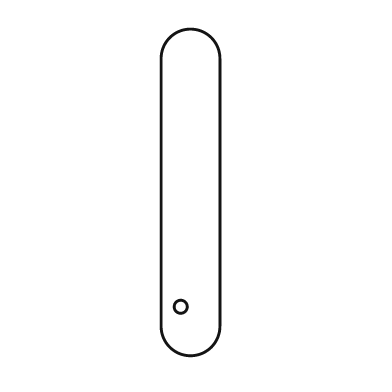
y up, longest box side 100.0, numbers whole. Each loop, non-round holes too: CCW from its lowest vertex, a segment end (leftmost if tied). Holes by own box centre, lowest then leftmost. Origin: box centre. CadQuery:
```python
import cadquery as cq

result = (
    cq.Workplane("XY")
    .moveTo(-9.0, -41.0)
    .threePointArc((0.0, -50.0), (9.0, -41.0))
    .lineTo(9.0, 41.0)
    .threePointArc((0.0, 50.0), (-9.0, 41.0))
    .close()
    .moveTo(-3.0, -35.0)
    .circle(2.0)
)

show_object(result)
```